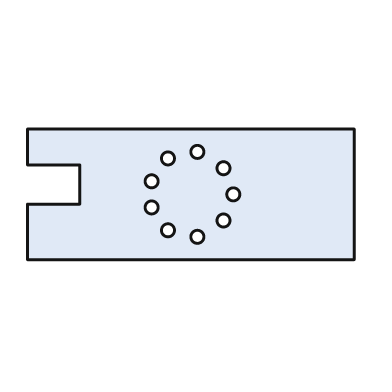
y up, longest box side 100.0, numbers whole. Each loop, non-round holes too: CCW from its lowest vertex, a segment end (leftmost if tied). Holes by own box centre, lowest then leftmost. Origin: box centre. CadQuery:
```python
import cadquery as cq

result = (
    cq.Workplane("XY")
    .moveTo(-50.0, -20.0)
    .lineTo(50.0, -20.0)
    .lineTo(50.0, 20.0)
    .lineTo(-50.0, 20.0)
    .lineTo(-50.0, 9.0)
    .lineTo(-34.0, 9.0)
    .lineTo(-34.0, -3.0)
    .lineTo(-50.0, -3.0)
    .close()
    .moveTo(2.0, -13.0)
    .circle(2.0)
    .moveTo(-7.0, -11.0)
    .circle(2.0)
    .moveTo(10.0, -8.0)
    .circle(2.0)
    .moveTo(-12.0, -4.0)
    .circle(2.0)
    .moveTo(13.0, 0.0)
    .circle(2.0)
    .moveTo(-12.0, 4.0)
    .circle(2.0)
    .moveTo(10.0, 8.0)
    .circle(2.0)
    .moveTo(-7.0, 11.0)
    .circle(2.0)
    .moveTo(2.0, 13.0)
    .circle(2.0)
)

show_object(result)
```